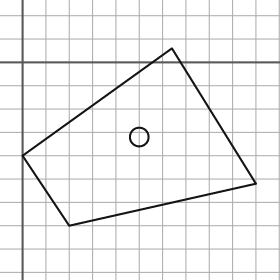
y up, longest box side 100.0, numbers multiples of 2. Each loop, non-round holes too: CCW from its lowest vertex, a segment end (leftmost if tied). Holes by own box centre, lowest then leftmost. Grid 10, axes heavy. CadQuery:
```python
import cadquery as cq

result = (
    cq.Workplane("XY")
    .moveTo(20.0, -70.0)
    .lineTo(100.0, -52.0)
    .lineTo(64.0, 6.0)
    .lineTo(0.0, -40.0)
    .close()
    .moveTo(50.0, -32.0)
    .circle(4.0)
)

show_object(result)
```